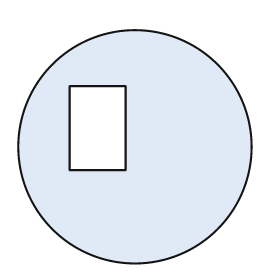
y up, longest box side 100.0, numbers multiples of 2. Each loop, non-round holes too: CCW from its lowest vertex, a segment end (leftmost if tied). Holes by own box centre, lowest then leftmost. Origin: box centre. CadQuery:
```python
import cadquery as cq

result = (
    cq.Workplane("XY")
    .moveTo(0.0, 0.0)
    .circle(50.0)
    .moveTo(-28.0, -10.0)
    .lineTo(-4.0, -10.0)
    .lineTo(-4.0, 26.0)
    .lineTo(-28.0, 26.0)
    .close()
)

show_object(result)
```